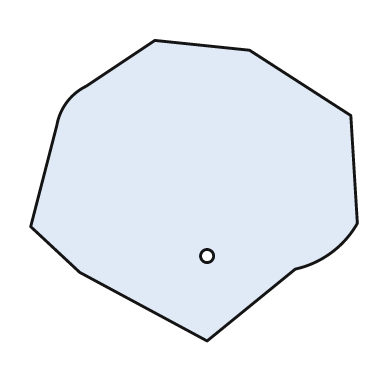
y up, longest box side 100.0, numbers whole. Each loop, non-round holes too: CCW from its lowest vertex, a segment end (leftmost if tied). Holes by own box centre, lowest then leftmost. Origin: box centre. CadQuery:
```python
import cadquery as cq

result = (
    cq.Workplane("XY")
    .moveTo(4.0, -46.0)
    .lineTo(31.0, -24.0)
    .threePointArc((42.0, -19.0), (50.0, -10.0))
    .lineTo(48.0, 23.0)
    .lineTo(17.0, 43.0)
    .lineTo(-12.0, 46.0)
    .lineTo(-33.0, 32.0)
    .threePointArc((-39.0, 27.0), (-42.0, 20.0))
    .lineTo(-50.0, -11.0)
    .lineTo(-35.0, -25.0)
    .close()
    .moveTo(4.0, -20.0)
    .circle(2.0)
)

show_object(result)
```